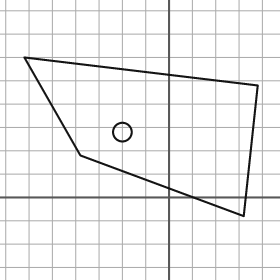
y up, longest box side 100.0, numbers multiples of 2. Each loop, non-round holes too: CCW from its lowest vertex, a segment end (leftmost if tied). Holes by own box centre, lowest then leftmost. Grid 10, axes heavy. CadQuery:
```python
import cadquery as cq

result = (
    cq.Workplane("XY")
    .moveTo(32.0, -8.0)
    .lineTo(38.0, 48.0)
    .lineTo(-62.0, 60.0)
    .lineTo(-38.0, 18.0)
    .close()
    .moveTo(-20.0, 28.0)
    .circle(4.0)
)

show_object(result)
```